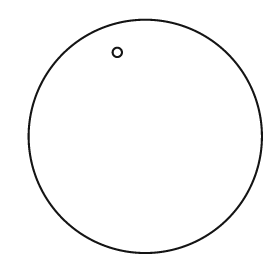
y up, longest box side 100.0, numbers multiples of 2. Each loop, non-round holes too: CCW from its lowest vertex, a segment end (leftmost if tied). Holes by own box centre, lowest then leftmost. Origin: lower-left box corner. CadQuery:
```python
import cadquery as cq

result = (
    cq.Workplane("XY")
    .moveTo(50.0, 50.0)
    .circle(50.0)
    .moveTo(38.0, 86.0)
    .circle(2.0)
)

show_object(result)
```